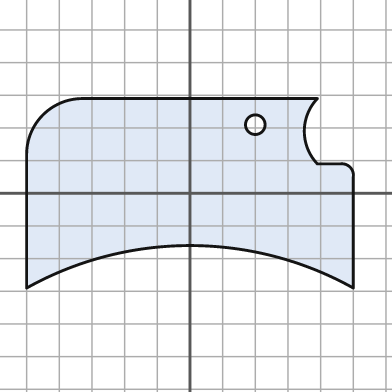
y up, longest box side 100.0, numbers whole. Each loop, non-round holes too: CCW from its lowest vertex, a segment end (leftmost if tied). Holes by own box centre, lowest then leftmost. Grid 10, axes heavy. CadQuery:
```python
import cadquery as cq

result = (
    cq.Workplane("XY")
    .moveTo(-50.0, -29.0)
    .threePointArc((0.0, -16.0), (50.0, -29.0))
    .lineTo(50.0, 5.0)
    .threePointArc((49.0, 8.0), (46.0, 9.0))
    .lineTo(39.0, 9.0)
    .threePointArc((35.0, 19.0), (39.0, 29.0))
    .lineTo(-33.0, 29.0)
    .threePointArc((-45.0, 24.0), (-50.0, 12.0))
    .close()
    .moveTo(20.0, 21.0)
    .circle(3.0)
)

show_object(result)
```